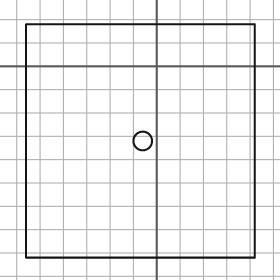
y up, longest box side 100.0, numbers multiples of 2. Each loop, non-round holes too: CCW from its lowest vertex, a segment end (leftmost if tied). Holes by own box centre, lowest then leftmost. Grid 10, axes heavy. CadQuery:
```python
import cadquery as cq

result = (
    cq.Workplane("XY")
    .moveTo(-56.0, -82.0)
    .lineTo(42.0, -82.0)
    .lineTo(42.0, 18.0)
    .lineTo(-56.0, 18.0)
    .close()
    .moveTo(-6.0, -32.0)
    .circle(4.0)
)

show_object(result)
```